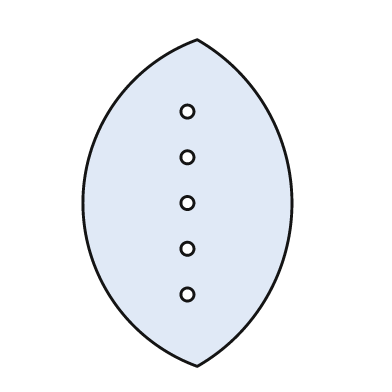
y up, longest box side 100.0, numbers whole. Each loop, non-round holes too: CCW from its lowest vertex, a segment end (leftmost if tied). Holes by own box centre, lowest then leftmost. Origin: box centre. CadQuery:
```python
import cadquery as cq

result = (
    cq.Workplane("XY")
    .moveTo(3.0, -50.0)
    .threePointArc((32.0, 0.0), (3.0, 50.0))
    .threePointArc((-32.0, 0.0), (3.0, -50.0))
    .close()
    .moveTo(0.0, -28.0)
    .circle(2.0)
    .moveTo(0.0, -14.0)
    .circle(2.0)
    .moveTo(0.0, 0.0)
    .circle(2.0)
    .moveTo(0.0, 14.0)
    .circle(2.0)
    .moveTo(0.0, 28.0)
    .circle(2.0)
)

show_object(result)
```